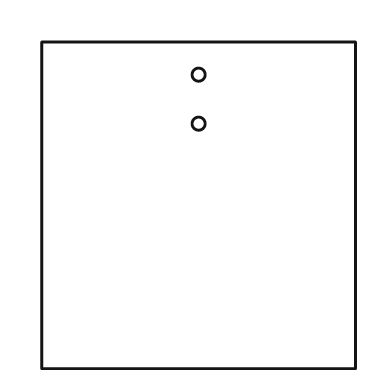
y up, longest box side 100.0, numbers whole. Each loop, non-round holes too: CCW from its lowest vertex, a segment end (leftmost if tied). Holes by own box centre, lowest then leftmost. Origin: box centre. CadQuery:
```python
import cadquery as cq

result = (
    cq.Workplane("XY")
    .moveTo(-48.0, -50.0)
    .lineTo(48.0, -50.0)
    .lineTo(48.0, 50.0)
    .lineTo(-48.0, 50.0)
    .close()
    .moveTo(0.0, 25.0)
    .circle(2.0)
    .moveTo(0.0, 40.0)
    .circle(2.0)
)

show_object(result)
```